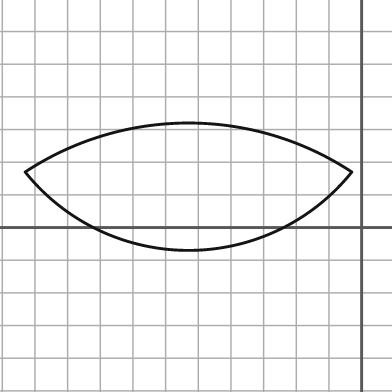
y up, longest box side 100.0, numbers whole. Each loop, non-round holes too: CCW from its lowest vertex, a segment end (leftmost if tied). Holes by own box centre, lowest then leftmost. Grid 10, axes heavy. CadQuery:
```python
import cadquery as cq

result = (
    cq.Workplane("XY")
    .moveTo(-103.0, 17.0)
    .threePointArc((-53.0, -7.0), (-3.0, 17.0))
    .threePointArc((-53.0, 32.0), (-103.0, 17.0))
    .close()
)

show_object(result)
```